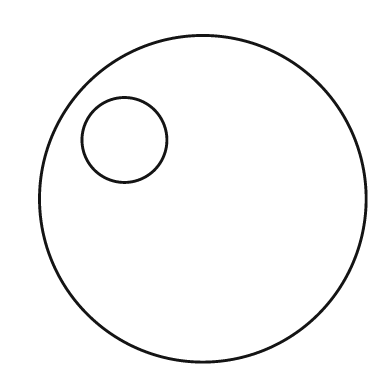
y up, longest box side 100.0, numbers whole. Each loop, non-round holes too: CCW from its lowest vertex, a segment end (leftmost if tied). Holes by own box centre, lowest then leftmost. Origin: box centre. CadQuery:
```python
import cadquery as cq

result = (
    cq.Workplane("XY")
    .moveTo(0.0, 0.0)
    .circle(50.0)
    .moveTo(-24.0, 18.0)
    .circle(13.0)
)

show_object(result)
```